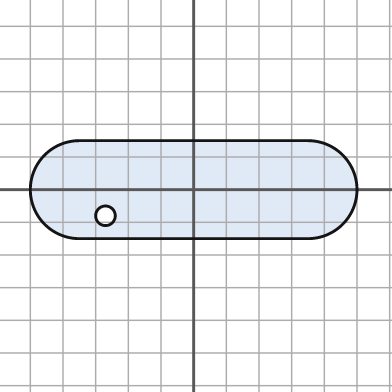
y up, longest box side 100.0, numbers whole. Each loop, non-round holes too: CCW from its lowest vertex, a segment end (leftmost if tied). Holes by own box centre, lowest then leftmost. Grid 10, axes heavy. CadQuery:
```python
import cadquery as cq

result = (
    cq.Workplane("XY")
    .moveTo(-35.0, -15.0)
    .lineTo(35.0, -15.0)
    .threePointArc((50.0, 0.0), (35.0, 15.0))
    .lineTo(-35.0, 15.0)
    .threePointArc((-50.0, 0.0), (-35.0, -15.0))
    .close()
    .moveTo(-27.0, -8.0)
    .circle(3.0)
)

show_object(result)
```